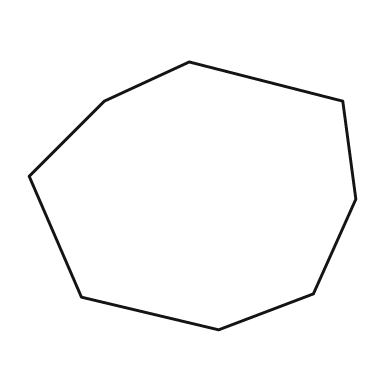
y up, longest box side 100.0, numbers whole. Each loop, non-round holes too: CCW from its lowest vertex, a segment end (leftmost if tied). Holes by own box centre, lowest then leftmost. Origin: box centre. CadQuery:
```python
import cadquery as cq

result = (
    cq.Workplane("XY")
    .moveTo(8.0, -41.0)
    .lineTo(37.0, -30.0)
    .lineTo(50.0, -1.0)
    .lineTo(46.0, 29.0)
    .lineTo(-1.0, 41.0)
    .lineTo(-27.0, 29.0)
    .lineTo(-50.0, 6.0)
    .lineTo(-34.0, -31.0)
    .close()
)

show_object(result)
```